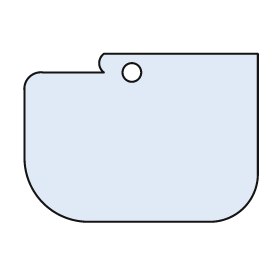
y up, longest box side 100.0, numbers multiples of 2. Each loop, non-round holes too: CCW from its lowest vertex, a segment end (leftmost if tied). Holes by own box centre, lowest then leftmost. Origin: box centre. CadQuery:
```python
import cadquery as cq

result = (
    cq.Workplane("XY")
    .moveTo(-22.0, -36.0)
    .lineTo(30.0, -36.0)
    .threePointArc((44.0, -30.0), (50.0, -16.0))
    .lineTo(50.0, 36.0)
    .lineTo(-16.0, 36.0)
    .threePointArc((-18.0, 32.0), (-16.0, 28.0))
    .lineTo(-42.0, 28.0)
    .threePointArc((-48.0, 26.0), (-50.0, 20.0))
    .lineTo(-50.0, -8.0)
    .threePointArc((-42.0, -28.0), (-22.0, -36.0))
    .close()
    .moveTo(-4.0, 28.0)
    .circle(4.0)
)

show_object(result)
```